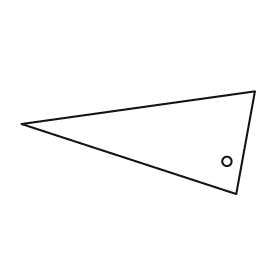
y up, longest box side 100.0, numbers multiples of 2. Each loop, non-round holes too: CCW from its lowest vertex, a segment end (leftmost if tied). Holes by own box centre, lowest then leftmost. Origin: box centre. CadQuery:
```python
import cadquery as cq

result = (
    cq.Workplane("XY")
    .moveTo(42.0, -22.0)
    .lineTo(50.0, 22.0)
    .lineTo(-50.0, 8.0)
    .close()
    .moveTo(38.0, -8.0)
    .circle(2.0)
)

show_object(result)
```